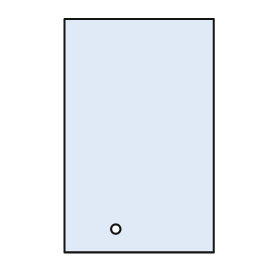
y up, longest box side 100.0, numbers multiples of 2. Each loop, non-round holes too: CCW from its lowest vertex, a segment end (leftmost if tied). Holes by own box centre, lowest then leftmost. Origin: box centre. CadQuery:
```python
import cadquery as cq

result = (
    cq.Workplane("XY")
    .moveTo(-32.0, -50.0)
    .lineTo(32.0, -50.0)
    .lineTo(32.0, 50.0)
    .lineTo(-32.0, 50.0)
    .close()
    .moveTo(-10.0, -40.0)
    .circle(2.0)
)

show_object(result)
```